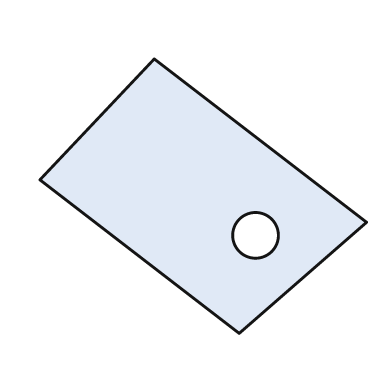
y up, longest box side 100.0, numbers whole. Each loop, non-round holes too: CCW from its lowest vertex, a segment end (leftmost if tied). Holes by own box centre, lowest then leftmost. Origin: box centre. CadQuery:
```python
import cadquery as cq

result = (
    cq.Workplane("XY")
    .moveTo(11.0, -42.0)
    .lineTo(50.0, -8.0)
    .lineTo(-15.0, 42.0)
    .lineTo(-50.0, 5.0)
    .close()
    .moveTo(16.0, -12.0)
    .circle(7.0)
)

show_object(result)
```